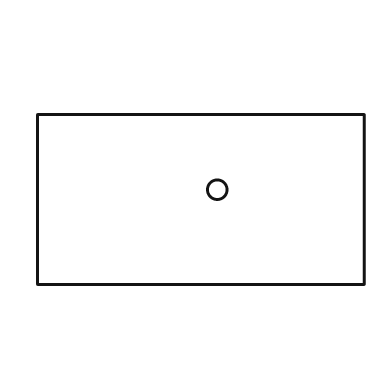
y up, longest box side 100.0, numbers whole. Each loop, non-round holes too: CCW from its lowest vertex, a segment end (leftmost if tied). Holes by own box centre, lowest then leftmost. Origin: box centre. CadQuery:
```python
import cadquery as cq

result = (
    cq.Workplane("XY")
    .moveTo(-50.0, -26.0)
    .lineTo(50.0, -26.0)
    .lineTo(50.0, 26.0)
    .lineTo(-50.0, 26.0)
    .close()
    .moveTo(5.0, 3.0)
    .circle(3.0)
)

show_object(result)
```